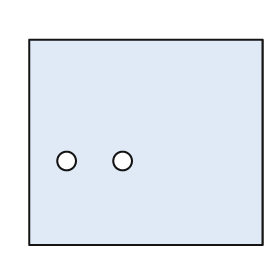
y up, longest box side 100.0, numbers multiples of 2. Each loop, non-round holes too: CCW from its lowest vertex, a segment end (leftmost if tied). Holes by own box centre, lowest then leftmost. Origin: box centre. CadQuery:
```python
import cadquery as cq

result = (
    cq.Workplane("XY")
    .moveTo(-50.0, -44.0)
    .lineTo(50.0, -44.0)
    .lineTo(50.0, 44.0)
    .lineTo(-50.0, 44.0)
    .close()
    .moveTo(-34.0, -8.0)
    .circle(4.0)
    .moveTo(-10.0, -8.0)
    .circle(4.0)
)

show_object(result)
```